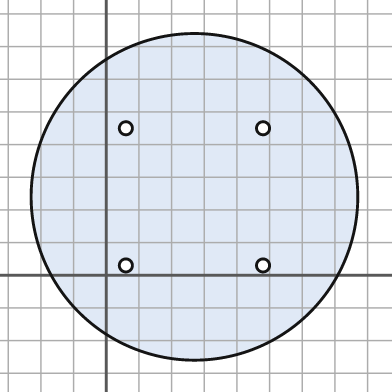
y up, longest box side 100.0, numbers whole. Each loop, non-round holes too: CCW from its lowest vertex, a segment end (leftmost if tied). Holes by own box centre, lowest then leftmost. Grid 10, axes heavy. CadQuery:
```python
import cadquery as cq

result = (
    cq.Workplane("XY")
    .moveTo(27.0, 24.0)
    .circle(50.0)
    .moveTo(6.0, 3.0)
    .circle(2.0)
    .moveTo(48.0, 3.0)
    .circle(2.0)
    .moveTo(6.0, 45.0)
    .circle(2.0)
    .moveTo(48.0, 45.0)
    .circle(2.0)
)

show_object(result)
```